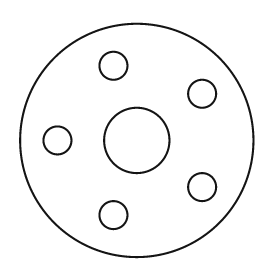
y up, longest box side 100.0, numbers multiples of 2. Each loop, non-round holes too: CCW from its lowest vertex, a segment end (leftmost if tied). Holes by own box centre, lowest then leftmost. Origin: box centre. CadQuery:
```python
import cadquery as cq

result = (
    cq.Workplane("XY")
    .moveTo(0.0, 0.0)
    .circle(50.0)
    .moveTo(-10.0, -32.0)
    .circle(6.0)
    .moveTo(28.0, -20.0)
    .circle(6.0)
    .moveTo(-34.0, 0.0)
    .circle(6.0)
    .moveTo(0.0, 0.0)
    .circle(14.0)
    .moveTo(28.0, 20.0)
    .circle(6.0)
    .moveTo(-10.0, 32.0)
    .circle(6.0)
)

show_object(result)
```